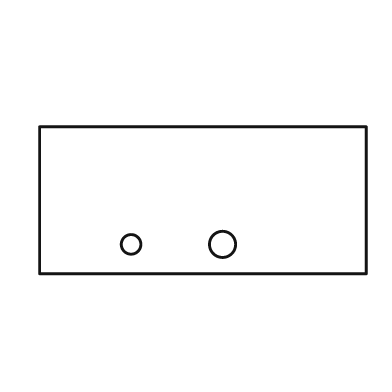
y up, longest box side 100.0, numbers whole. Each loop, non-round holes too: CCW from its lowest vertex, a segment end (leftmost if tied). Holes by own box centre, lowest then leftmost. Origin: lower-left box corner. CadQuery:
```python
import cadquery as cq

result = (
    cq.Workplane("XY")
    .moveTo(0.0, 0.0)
    .lineTo(100.0, 0.0)
    .lineTo(100.0, 45.0)
    .lineTo(0.0, 45.0)
    .close()
    .moveTo(28.0, 9.0)
    .circle(3.0)
    .moveTo(56.0, 9.0)
    .circle(4.0)
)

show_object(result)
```